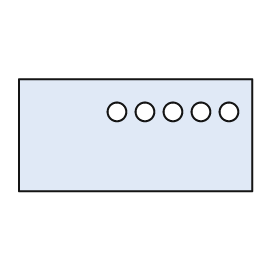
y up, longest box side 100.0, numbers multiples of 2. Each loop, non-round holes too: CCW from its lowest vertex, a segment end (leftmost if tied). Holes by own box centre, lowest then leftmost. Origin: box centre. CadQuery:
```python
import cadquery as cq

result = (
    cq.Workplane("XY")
    .moveTo(-50.0, -24.0)
    .lineTo(50.0, -24.0)
    .lineTo(50.0, 24.0)
    .lineTo(-50.0, 24.0)
    .close()
    .moveTo(-8.0, 10.0)
    .circle(4.0)
    .moveTo(4.0, 10.0)
    .circle(4.0)
    .moveTo(16.0, 10.0)
    .circle(4.0)
    .moveTo(28.0, 10.0)
    .circle(4.0)
    .moveTo(40.0, 10.0)
    .circle(4.0)
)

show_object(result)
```